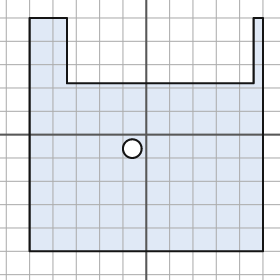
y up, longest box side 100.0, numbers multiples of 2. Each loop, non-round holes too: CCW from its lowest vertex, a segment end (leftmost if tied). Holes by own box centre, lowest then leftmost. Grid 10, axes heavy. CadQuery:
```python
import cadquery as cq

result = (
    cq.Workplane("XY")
    .moveTo(-50.0, -50.0)
    .lineTo(50.0, -50.0)
    .lineTo(50.0, 50.0)
    .lineTo(46.0, 50.0)
    .lineTo(46.0, 22.0)
    .lineTo(-34.0, 22.0)
    .lineTo(-34.0, 50.0)
    .lineTo(-50.0, 50.0)
    .close()
    .moveTo(-6.0, -6.0)
    .circle(4.0)
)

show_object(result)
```